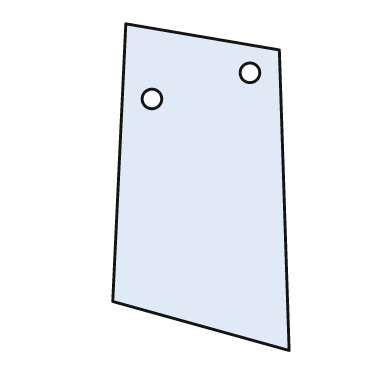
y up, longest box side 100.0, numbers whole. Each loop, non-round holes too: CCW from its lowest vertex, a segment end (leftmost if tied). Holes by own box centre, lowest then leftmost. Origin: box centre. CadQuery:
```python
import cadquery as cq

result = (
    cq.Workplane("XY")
    .moveTo(27.0, -50.0)
    .lineTo(24.0, 42.0)
    .lineTo(-23.0, 50.0)
    .lineTo(-27.0, -35.0)
    .close()
    .moveTo(-15.0, 27.0)
    .circle(3.0)
    .moveTo(15.0, 35.0)
    .circle(3.0)
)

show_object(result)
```